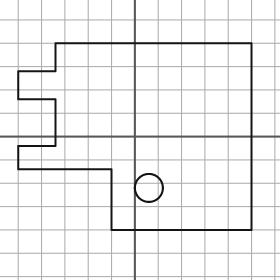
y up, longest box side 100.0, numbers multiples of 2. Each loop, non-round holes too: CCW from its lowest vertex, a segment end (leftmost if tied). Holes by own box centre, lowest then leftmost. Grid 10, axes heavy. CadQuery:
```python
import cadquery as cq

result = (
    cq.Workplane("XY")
    .moveTo(-10.0, -40.0)
    .lineTo(50.0, -40.0)
    .lineTo(50.0, 40.0)
    .lineTo(-34.0, 40.0)
    .lineTo(-34.0, 28.0)
    .lineTo(-50.0, 28.0)
    .lineTo(-50.0, 16.0)
    .lineTo(-34.0, 16.0)
    .lineTo(-34.0, -4.0)
    .lineTo(-50.0, -4.0)
    .lineTo(-50.0, -14.0)
    .lineTo(-10.0, -14.0)
    .close()
    .moveTo(6.0, -22.0)
    .circle(6.0)
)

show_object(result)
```